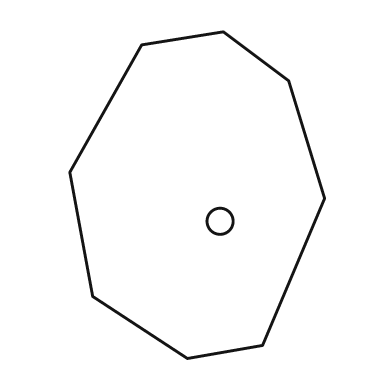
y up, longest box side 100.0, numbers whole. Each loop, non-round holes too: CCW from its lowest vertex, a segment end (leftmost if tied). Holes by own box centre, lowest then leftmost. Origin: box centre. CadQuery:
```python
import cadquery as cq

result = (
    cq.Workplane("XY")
    .moveTo(-3.0, -50.0)
    .lineTo(20.0, -46.0)
    .lineTo(39.0, -1.0)
    .lineTo(28.0, 35.0)
    .lineTo(8.0, 50.0)
    .lineTo(-17.0, 46.0)
    .lineTo(-39.0, 7.0)
    .lineTo(-32.0, -31.0)
    .close()
    .moveTo(7.0, -8.0)
    .circle(4.0)
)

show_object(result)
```